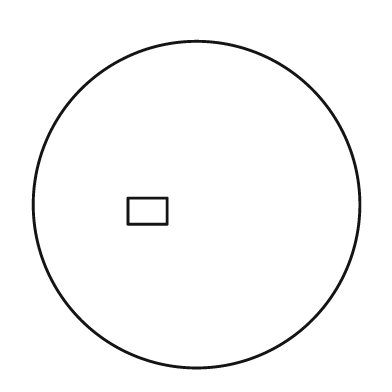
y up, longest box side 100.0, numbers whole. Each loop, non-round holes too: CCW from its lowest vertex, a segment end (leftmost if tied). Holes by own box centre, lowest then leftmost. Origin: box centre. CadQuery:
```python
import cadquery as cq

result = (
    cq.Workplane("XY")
    .moveTo(0.0, 0.0)
    .circle(50.0)
    .moveTo(-21.0, -6.0)
    .lineTo(-9.0, -6.0)
    .lineTo(-9.0, 2.0)
    .lineTo(-21.0, 2.0)
    .close()
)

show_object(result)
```